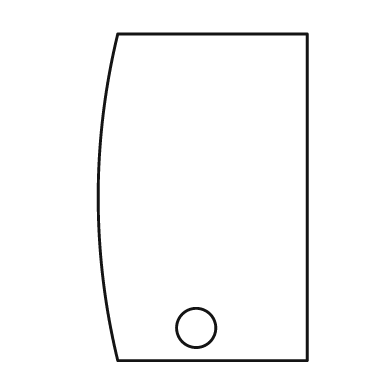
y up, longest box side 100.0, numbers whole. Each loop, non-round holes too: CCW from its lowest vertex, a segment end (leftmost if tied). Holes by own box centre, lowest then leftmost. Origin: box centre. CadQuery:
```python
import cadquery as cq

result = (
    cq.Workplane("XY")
    .moveTo(-26.0, -50.0)
    .lineTo(32.0, -50.0)
    .lineTo(32.0, 50.0)
    .lineTo(-26.0, 50.0)
    .threePointArc((-32.0, 0.0), (-26.0, -50.0))
    .close()
    .moveTo(-2.0, -40.0)
    .circle(6.0)
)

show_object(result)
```